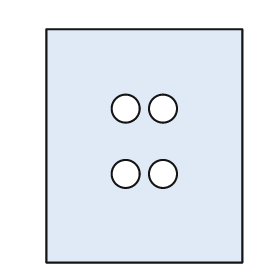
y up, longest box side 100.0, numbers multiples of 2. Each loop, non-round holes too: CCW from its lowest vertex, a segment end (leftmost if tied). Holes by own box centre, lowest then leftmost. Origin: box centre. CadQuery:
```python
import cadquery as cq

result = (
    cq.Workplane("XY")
    .moveTo(-42.0, -50.0)
    .lineTo(42.0, -50.0)
    .lineTo(42.0, 50.0)
    .lineTo(-42.0, 50.0)
    .close()
    .moveTo(-8.0, -12.0)
    .circle(6.0)
    .moveTo(8.0, -12.0)
    .circle(6.0)
    .moveTo(-8.0, 16.0)
    .circle(6.0)
    .moveTo(8.0, 16.0)
    .circle(6.0)
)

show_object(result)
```